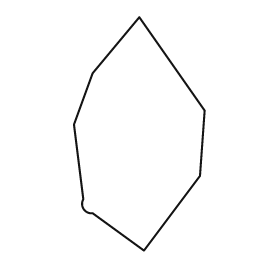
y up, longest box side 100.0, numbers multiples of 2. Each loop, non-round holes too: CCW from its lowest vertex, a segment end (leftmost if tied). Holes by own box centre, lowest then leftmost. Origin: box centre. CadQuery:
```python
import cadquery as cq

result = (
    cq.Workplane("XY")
    .moveTo(2.0, -50.0)
    .lineTo(26.0, -18.0)
    .lineTo(28.0, 10.0)
    .lineTo(0.0, 50.0)
    .lineTo(-20.0, 26.0)
    .lineTo(-28.0, 4.0)
    .lineTo(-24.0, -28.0)
    .threePointArc((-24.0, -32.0), (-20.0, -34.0))
    .close()
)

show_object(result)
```